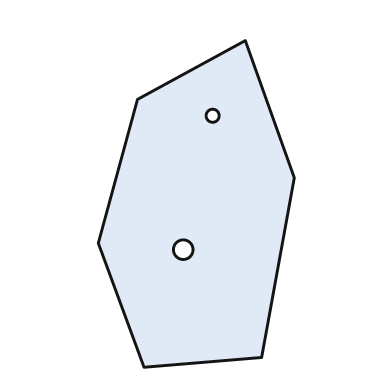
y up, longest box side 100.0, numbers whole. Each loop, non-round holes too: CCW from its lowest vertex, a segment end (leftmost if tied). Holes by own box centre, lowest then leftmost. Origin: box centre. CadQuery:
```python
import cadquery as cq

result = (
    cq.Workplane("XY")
    .moveTo(-16.0, -50.0)
    .lineTo(20.0, -47.0)
    .lineTo(30.0, 8.0)
    .lineTo(15.0, 50.0)
    .lineTo(-18.0, 32.0)
    .lineTo(-30.0, -12.0)
    .close()
    .moveTo(-4.0, -14.0)
    .circle(3.0)
    .moveTo(5.0, 27.0)
    .circle(2.0)
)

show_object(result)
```